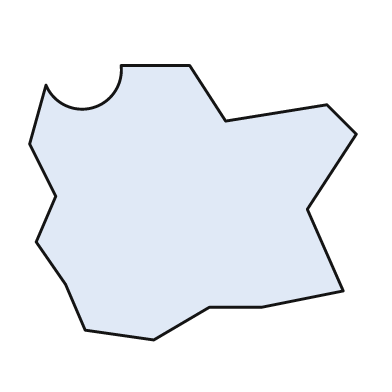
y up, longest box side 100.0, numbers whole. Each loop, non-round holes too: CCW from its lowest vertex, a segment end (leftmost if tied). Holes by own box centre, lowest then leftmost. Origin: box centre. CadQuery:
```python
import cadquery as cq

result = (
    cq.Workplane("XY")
    .moveTo(-12.0, -42.0)
    .lineTo(5.0, -32.0)
    .lineTo(21.0, -32.0)
    .lineTo(46.0, -27.0)
    .lineTo(35.0, -2.0)
    .lineTo(50.0, 21.0)
    .lineTo(41.0, 30.0)
    .lineTo(10.0, 25.0)
    .lineTo(-1.0, 42.0)
    .lineTo(-22.0, 42.0)
    .threePointArc((-31.0, 29.0), (-45.0, 36.0))
    .lineTo(-50.0, 18.0)
    .lineTo(-42.0, 2.0)
    .lineTo(-48.0, -12.0)
    .lineTo(-39.0, -25.0)
    .lineTo(-33.0, -39.0)
    .close()
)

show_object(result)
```